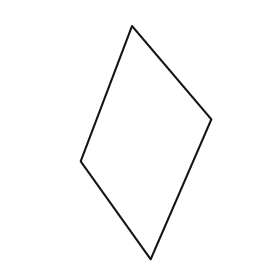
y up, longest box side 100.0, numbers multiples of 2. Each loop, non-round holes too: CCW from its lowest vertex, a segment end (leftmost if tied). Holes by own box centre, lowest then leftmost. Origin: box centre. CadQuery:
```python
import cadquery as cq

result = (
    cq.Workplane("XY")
    .moveTo(2.0, -50.0)
    .lineTo(28.0, 10.0)
    .lineTo(-6.0, 50.0)
    .lineTo(-28.0, -8.0)
    .close()
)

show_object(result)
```